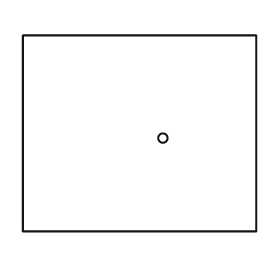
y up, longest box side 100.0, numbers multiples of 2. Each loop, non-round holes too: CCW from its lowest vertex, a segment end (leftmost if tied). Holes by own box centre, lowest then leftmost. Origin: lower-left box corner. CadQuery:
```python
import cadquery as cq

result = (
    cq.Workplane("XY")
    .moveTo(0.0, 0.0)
    .lineTo(100.0, 0.0)
    .lineTo(100.0, 84.0)
    .lineTo(0.0, 84.0)
    .close()
    .moveTo(60.0, 40.0)
    .circle(2.0)
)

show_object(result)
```